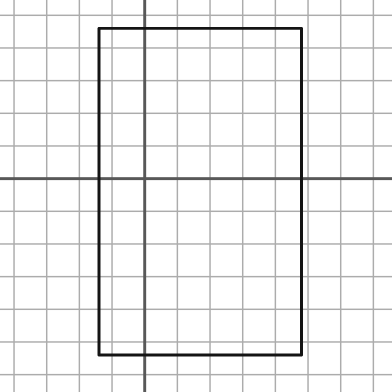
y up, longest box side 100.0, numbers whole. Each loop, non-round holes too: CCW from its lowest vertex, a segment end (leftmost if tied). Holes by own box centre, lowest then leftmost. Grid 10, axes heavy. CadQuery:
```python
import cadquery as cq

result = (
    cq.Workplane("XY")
    .moveTo(-14.0, -54.0)
    .lineTo(48.0, -54.0)
    .lineTo(48.0, 46.0)
    .lineTo(-14.0, 46.0)
    .close()
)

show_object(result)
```